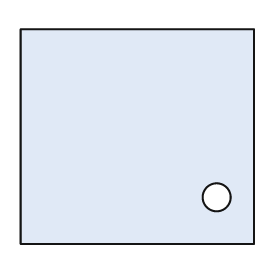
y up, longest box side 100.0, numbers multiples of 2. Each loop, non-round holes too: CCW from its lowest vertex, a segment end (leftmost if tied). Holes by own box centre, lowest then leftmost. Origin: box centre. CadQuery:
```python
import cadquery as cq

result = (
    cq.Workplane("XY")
    .moveTo(-50.0, -46.0)
    .lineTo(50.0, -46.0)
    .lineTo(50.0, 46.0)
    .lineTo(-50.0, 46.0)
    .close()
    .moveTo(34.0, -26.0)
    .circle(6.0)
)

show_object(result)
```